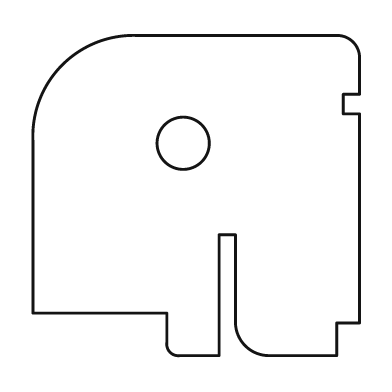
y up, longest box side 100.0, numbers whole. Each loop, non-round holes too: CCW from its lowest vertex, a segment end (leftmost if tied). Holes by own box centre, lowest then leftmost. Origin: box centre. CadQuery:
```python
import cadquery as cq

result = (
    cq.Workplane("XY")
    .moveTo(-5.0, -49.0)
    .lineTo(7.0, -49.0)
    .lineTo(7.0, -12.0)
    .lineTo(12.0, -12.0)
    .lineTo(12.0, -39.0)
    .threePointArc((15.0, -46.0), (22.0, -49.0))
    .lineTo(43.0, -49.0)
    .lineTo(43.0, -39.0)
    .lineTo(50.0, -39.0)
    .lineTo(50.0, 25.0)
    .lineTo(45.0, 25.0)
    .lineTo(45.0, 31.0)
    .lineTo(50.0, 31.0)
    .lineTo(50.0, 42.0)
    .threePointArc((48.0, 47.0), (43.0, 49.0))
    .lineTo(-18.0, 49.0)
    .threePointArc((-41.0, 40.0), (-50.0, 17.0))
    .lineTo(-50.0, -36.0)
    .lineTo(-9.0, -36.0)
    .lineTo(-9.0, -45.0)
    .threePointArc((-8.0, -48.0), (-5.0, -49.0))
    .close()
    .moveTo(-4.0, 16.0)
    .circle(8.0)
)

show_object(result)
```